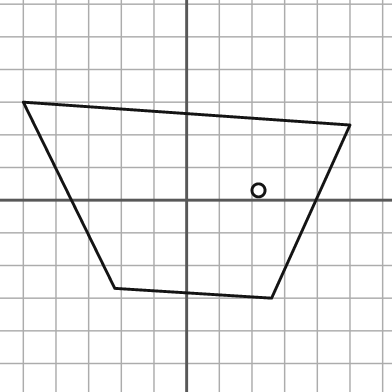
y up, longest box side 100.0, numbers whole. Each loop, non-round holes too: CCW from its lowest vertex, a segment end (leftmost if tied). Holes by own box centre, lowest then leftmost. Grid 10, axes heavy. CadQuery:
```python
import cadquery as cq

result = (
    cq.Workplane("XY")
    .moveTo(26.0, -30.0)
    .lineTo(50.0, 23.0)
    .lineTo(-50.0, 30.0)
    .lineTo(-22.0, -27.0)
    .close()
    .moveTo(22.0, 3.0)
    .circle(2.0)
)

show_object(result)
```